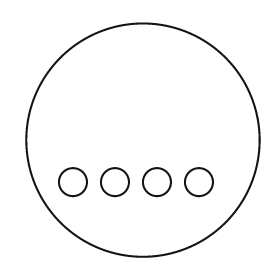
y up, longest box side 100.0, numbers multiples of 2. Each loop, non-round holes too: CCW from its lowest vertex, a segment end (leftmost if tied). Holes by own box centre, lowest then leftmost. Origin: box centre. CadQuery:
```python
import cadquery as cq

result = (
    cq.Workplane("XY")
    .moveTo(0.0, 0.0)
    .circle(50.0)
    .moveTo(-30.0, -18.0)
    .circle(6.0)
    .moveTo(-12.0, -18.0)
    .circle(6.0)
    .moveTo(6.0, -18.0)
    .circle(6.0)
    .moveTo(24.0, -18.0)
    .circle(6.0)
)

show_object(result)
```